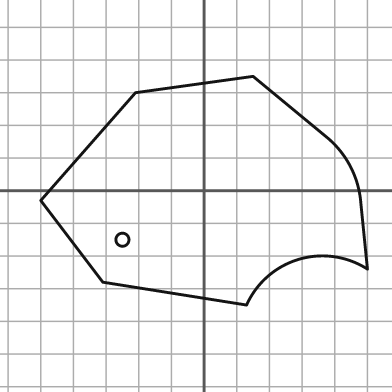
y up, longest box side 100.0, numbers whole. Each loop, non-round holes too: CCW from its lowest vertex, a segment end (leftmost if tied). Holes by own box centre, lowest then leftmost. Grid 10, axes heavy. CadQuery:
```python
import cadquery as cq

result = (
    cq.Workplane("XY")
    .moveTo(13.0, -35.0)
    .threePointArc((29.0, -21.0), (50.0, -24.0))
    .lineTo(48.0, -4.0)
    .threePointArc((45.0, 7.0), (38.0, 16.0))
    .lineTo(15.0, 35.0)
    .lineTo(-21.0, 30.0)
    .lineTo(-50.0, -3.0)
    .lineTo(-31.0, -28.0)
    .close()
    .moveTo(-25.0, -15.0)
    .circle(2.0)
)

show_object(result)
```